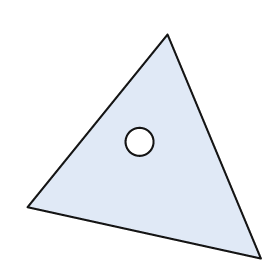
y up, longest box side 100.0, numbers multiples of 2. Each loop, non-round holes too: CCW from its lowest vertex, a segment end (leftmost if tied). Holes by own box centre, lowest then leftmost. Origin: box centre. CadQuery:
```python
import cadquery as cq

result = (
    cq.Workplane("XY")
    .moveTo(50.0, -48.0)
    .lineTo(10.0, 48.0)
    .lineTo(-50.0, -26.0)
    .close()
    .moveTo(-2.0, 2.0)
    .circle(6.0)
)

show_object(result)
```